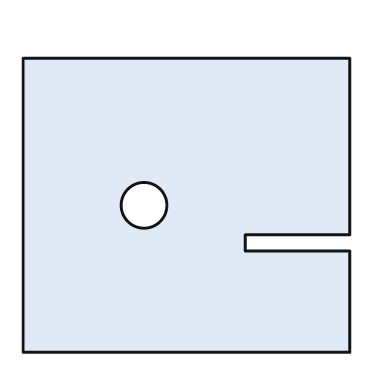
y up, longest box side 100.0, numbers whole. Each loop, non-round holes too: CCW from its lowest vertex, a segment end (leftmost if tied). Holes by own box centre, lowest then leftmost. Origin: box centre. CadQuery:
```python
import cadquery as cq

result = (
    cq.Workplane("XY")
    .moveTo(-50.0, -45.0)
    .lineTo(50.0, -45.0)
    .lineTo(50.0, -14.0)
    .lineTo(18.0, -14.0)
    .lineTo(18.0, -9.0)
    .lineTo(50.0, -9.0)
    .lineTo(50.0, 45.0)
    .lineTo(-50.0, 45.0)
    .close()
    .moveTo(-13.0, 0.0)
    .circle(7.0)
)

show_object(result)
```